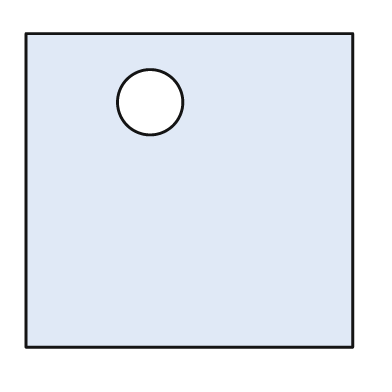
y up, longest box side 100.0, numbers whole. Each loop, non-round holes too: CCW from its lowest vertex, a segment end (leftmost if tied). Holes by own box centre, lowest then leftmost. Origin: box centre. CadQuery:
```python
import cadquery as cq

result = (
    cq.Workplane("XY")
    .moveTo(-50.0, -48.0)
    .lineTo(50.0, -48.0)
    .lineTo(50.0, 48.0)
    .lineTo(-50.0, 48.0)
    .close()
    .moveTo(-12.0, 27.0)
    .circle(10.0)
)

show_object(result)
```